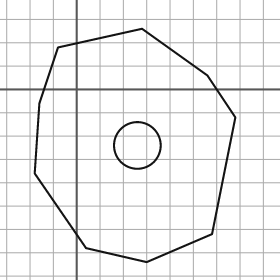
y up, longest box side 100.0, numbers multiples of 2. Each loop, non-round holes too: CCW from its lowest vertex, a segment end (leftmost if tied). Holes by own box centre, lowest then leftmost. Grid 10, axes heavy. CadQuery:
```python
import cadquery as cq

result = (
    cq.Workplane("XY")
    .moveTo(30.0, -74.0)
    .lineTo(58.0, -62.0)
    .lineTo(68.0, -12.0)
    .lineTo(56.0, 6.0)
    .lineTo(28.0, 26.0)
    .lineTo(-8.0, 18.0)
    .lineTo(-16.0, -6.0)
    .lineTo(-18.0, -36.0)
    .lineTo(4.0, -68.0)
    .close()
    .moveTo(26.0, -24.0)
    .circle(10.0)
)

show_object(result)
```